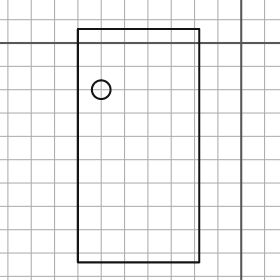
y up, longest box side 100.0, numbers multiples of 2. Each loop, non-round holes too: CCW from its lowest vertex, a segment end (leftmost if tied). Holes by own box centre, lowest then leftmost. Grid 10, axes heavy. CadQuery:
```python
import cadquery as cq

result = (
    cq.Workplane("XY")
    .moveTo(-70.0, -94.0)
    .lineTo(-18.0, -94.0)
    .lineTo(-18.0, 6.0)
    .lineTo(-70.0, 6.0)
    .close()
    .moveTo(-60.0, -20.0)
    .circle(4.0)
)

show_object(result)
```